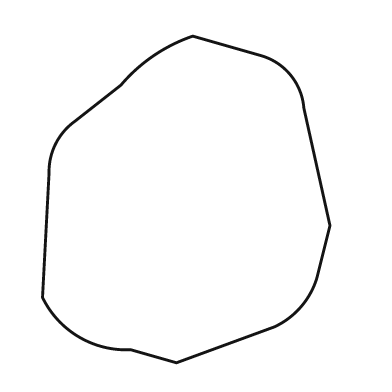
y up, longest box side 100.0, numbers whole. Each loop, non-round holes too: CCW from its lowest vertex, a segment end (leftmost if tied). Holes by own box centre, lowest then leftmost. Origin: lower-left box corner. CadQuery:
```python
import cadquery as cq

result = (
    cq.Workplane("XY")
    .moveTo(41.0, 0.0)
    .lineTo(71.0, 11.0)
    .threePointArc((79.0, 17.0), (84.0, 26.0))
    .lineTo(88.0, 42.0)
    .lineTo(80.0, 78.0)
    .threePointArc((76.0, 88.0), (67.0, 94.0))
    .lineTo(46.0, 100.0)
    .threePointArc((34.0, 94.0), (24.0, 85.0))
    .lineTo(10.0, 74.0)
    .threePointArc((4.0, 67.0), (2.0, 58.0))
    .lineTo(0.0, 20.0)
    .threePointArc((11.0, 8.0), (27.0, 4.0))
    .close()
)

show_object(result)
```